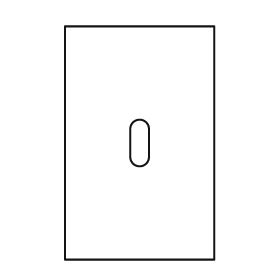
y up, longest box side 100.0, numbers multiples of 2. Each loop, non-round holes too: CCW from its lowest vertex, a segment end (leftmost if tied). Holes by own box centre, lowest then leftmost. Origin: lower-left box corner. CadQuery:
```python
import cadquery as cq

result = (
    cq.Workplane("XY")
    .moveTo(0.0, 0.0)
    .lineTo(64.0, 0.0)
    .lineTo(64.0, 100.0)
    .lineTo(0.0, 100.0)
    .close()
    .moveTo(28.0, 44.0)
    .threePointArc((32.0, 40.0), (36.0, 44.0))
    .lineTo(36.0, 56.0)
    .threePointArc((32.0, 60.0), (28.0, 56.0))
    .close()
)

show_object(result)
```